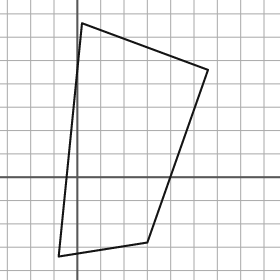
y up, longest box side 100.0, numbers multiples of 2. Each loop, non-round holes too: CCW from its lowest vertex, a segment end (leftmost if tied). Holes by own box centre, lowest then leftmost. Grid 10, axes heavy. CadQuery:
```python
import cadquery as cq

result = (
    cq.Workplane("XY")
    .moveTo(-8.0, -34.0)
    .lineTo(30.0, -28.0)
    .lineTo(56.0, 46.0)
    .lineTo(2.0, 66.0)
    .close()
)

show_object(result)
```